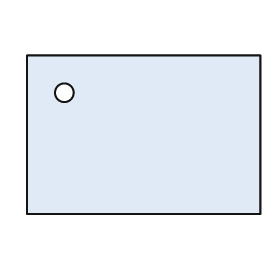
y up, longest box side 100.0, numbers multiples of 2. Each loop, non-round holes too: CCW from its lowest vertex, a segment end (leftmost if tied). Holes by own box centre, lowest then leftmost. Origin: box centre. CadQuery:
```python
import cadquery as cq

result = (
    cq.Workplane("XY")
    .moveTo(-50.0, -34.0)
    .lineTo(50.0, -34.0)
    .lineTo(50.0, 34.0)
    .lineTo(-50.0, 34.0)
    .close()
    .moveTo(-34.0, 18.0)
    .circle(4.0)
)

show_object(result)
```